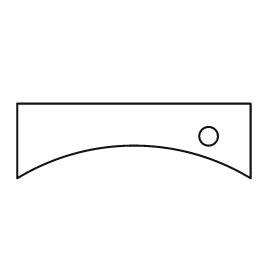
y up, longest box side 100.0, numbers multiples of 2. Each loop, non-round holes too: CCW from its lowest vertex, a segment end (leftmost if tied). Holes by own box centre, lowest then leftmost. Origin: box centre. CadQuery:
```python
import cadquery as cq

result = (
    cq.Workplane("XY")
    .moveTo(-50.0, -16.0)
    .threePointArc((0.0, -2.0), (50.0, -16.0))
    .lineTo(50.0, 16.0)
    .lineTo(-50.0, 16.0)
    .close()
    .moveTo(32.0, 2.0)
    .circle(4.0)
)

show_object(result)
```